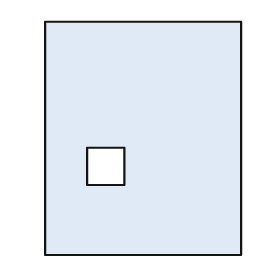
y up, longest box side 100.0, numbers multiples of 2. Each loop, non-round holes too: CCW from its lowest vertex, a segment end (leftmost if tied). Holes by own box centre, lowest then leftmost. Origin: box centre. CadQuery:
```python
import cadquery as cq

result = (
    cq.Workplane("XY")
    .moveTo(-42.0, -50.0)
    .lineTo(42.0, -50.0)
    .lineTo(42.0, 50.0)
    .lineTo(-42.0, 50.0)
    .close()
    .moveTo(-24.0, -20.0)
    .lineTo(-8.0, -20.0)
    .lineTo(-8.0, -4.0)
    .lineTo(-24.0, -4.0)
    .close()
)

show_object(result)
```